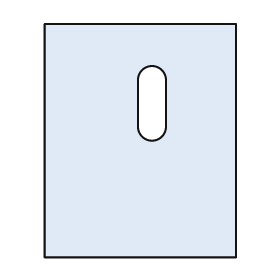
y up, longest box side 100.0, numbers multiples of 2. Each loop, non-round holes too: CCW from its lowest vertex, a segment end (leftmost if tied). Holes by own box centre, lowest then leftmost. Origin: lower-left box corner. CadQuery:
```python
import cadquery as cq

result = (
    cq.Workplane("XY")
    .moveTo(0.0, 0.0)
    .lineTo(82.0, 0.0)
    .lineTo(82.0, 100.0)
    .lineTo(0.0, 100.0)
    .close()
    .moveTo(40.0, 56.0)
    .threePointArc((46.0, 50.0), (52.0, 56.0))
    .lineTo(52.0, 76.0)
    .threePointArc((46.0, 82.0), (40.0, 76.0))
    .close()
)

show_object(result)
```